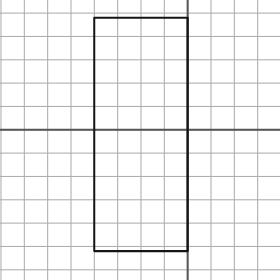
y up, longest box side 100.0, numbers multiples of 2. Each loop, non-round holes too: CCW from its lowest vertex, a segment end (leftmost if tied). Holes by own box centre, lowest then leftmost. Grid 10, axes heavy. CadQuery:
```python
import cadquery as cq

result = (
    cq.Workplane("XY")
    .moveTo(-40.0, -52.0)
    .lineTo(0.0, -52.0)
    .lineTo(0.0, 48.0)
    .lineTo(-40.0, 48.0)
    .close()
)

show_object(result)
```